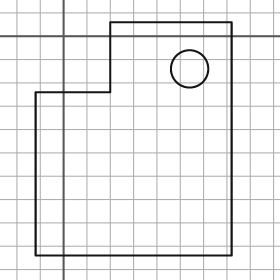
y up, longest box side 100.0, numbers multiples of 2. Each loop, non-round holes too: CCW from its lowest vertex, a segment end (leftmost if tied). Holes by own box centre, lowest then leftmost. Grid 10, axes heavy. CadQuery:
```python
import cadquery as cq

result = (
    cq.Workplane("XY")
    .moveTo(-12.0, -94.0)
    .lineTo(72.0, -94.0)
    .lineTo(72.0, 6.0)
    .lineTo(20.0, 6.0)
    .lineTo(20.0, -24.0)
    .lineTo(-12.0, -24.0)
    .close()
    .moveTo(54.0, -14.0)
    .circle(8.0)
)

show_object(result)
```